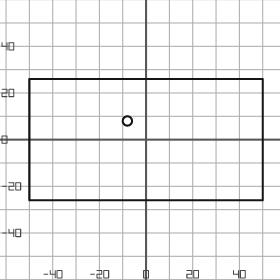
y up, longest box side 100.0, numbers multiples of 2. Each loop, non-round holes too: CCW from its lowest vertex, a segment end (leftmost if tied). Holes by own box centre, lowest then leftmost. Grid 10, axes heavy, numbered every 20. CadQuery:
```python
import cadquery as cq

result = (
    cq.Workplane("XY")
    .moveTo(-50.0, -26.0)
    .lineTo(50.0, -26.0)
    .lineTo(50.0, 26.0)
    .lineTo(-50.0, 26.0)
    .close()
    .moveTo(-8.0, 8.0)
    .circle(2.0)
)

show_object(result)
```